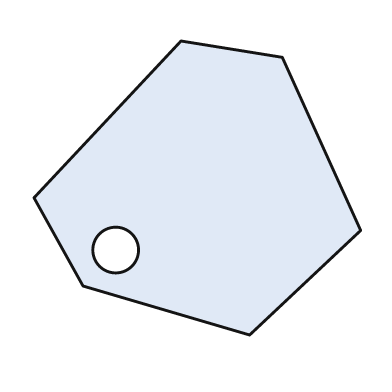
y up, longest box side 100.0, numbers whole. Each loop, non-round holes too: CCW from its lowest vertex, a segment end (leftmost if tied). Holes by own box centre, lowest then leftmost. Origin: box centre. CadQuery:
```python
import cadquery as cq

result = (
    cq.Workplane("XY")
    .moveTo(16.0, -45.0)
    .lineTo(50.0, -13.0)
    .lineTo(26.0, 40.0)
    .lineTo(-5.0, 45.0)
    .lineTo(-50.0, -3.0)
    .lineTo(-35.0, -30.0)
    .close()
    .moveTo(-25.0, -19.0)
    .circle(7.0)
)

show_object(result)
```